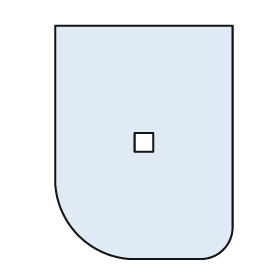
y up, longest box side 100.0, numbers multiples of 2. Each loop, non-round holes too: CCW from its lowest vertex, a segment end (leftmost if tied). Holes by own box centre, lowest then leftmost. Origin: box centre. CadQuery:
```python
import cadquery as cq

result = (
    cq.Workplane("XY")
    .moveTo(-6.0, -50.0)
    .lineTo(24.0, -50.0)
    .threePointArc((34.0, -46.0), (38.0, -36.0))
    .lineTo(38.0, 50.0)
    .lineTo(-38.0, 50.0)
    .lineTo(-38.0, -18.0)
    .threePointArc((-28.0, -40.0), (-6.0, -50.0))
    .close()
    .moveTo(-4.0, -4.0)
    .lineTo(4.0, -4.0)
    .lineTo(4.0, 4.0)
    .lineTo(-4.0, 4.0)
    .close()
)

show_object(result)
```